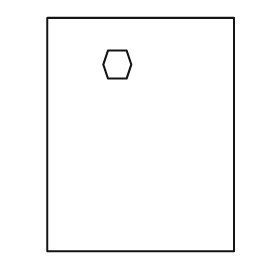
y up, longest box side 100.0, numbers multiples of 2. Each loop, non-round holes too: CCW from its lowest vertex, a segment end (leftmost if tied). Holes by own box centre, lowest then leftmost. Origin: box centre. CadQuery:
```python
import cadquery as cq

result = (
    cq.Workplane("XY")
    .moveTo(-40.0, -50.0)
    .lineTo(40.0, -50.0)
    .lineTo(40.0, 50.0)
    .lineTo(-40.0, 50.0)
    .close()
    .moveTo(-14.0, 24.0)
    .lineTo(-6.0, 24.0)
    .lineTo(-4.0, 30.0)
    .lineTo(-6.0, 36.0)
    .lineTo(-14.0, 36.0)
    .lineTo(-16.0, 30.0)
    .close()
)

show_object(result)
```